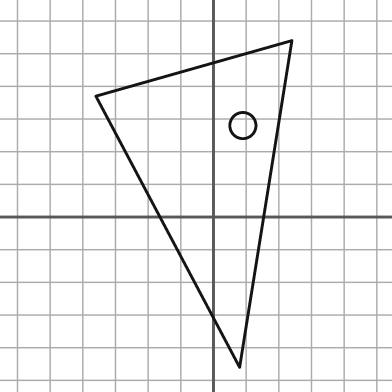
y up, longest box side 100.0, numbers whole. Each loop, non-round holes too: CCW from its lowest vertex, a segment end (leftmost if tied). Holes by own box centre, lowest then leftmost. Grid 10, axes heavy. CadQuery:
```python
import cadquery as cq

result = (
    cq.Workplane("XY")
    .moveTo(8.0, -46.0)
    .lineTo(24.0, 54.0)
    .lineTo(-36.0, 37.0)
    .close()
    .moveTo(9.0, 28.0)
    .circle(4.0)
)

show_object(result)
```